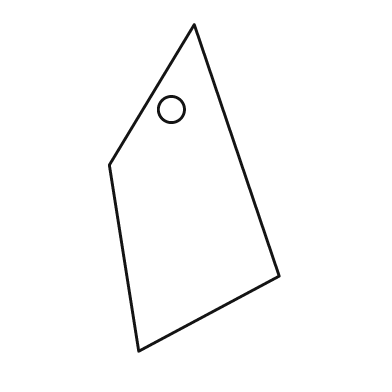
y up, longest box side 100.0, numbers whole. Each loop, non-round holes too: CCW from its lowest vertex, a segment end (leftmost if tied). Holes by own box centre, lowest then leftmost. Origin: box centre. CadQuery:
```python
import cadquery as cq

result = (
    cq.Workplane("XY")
    .moveTo(-17.0, -50.0)
    .lineTo(26.0, -27.0)
    .lineTo(0.0, 50.0)
    .lineTo(-26.0, 7.0)
    .close()
    .moveTo(-7.0, 24.0)
    .circle(4.0)
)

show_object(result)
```